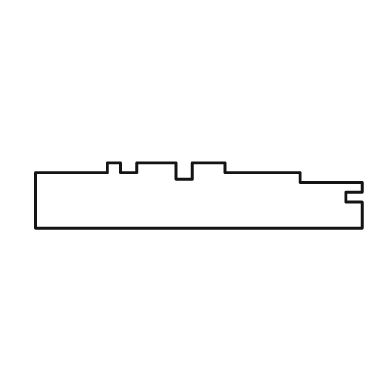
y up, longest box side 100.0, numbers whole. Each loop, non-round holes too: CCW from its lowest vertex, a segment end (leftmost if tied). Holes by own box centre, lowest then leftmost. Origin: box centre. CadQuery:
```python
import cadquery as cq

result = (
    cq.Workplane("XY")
    .moveTo(-50.0, -10.0)
    .lineTo(50.0, -10.0)
    .lineTo(50.0, -2.0)
    .lineTo(45.0, -2.0)
    .lineTo(45.0, 1.0)
    .lineTo(50.0, 1.0)
    .lineTo(50.0, 4.0)
    .lineTo(31.0, 4.0)
    .lineTo(31.0, 7.0)
    .lineTo(8.0, 7.0)
    .lineTo(8.0, 10.0)
    .lineTo(-2.0, 10.0)
    .lineTo(-2.0, 5.0)
    .lineTo(-7.0, 5.0)
    .lineTo(-7.0, 10.0)
    .lineTo(-19.0, 10.0)
    .lineTo(-19.0, 7.0)
    .lineTo(-24.0, 7.0)
    .lineTo(-24.0, 10.0)
    .lineTo(-28.0, 10.0)
    .lineTo(-28.0, 7.0)
    .lineTo(-50.0, 7.0)
    .close()
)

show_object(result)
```